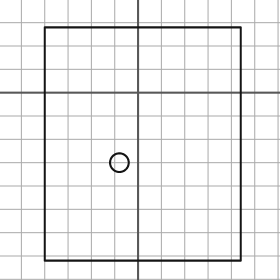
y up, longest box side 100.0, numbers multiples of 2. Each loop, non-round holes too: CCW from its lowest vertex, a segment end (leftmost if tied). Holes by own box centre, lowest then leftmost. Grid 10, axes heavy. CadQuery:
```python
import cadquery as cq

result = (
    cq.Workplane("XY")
    .moveTo(-40.0, -72.0)
    .lineTo(44.0, -72.0)
    .lineTo(44.0, 28.0)
    .lineTo(-40.0, 28.0)
    .close()
    .moveTo(-8.0, -30.0)
    .circle(4.0)
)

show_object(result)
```